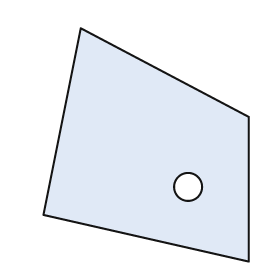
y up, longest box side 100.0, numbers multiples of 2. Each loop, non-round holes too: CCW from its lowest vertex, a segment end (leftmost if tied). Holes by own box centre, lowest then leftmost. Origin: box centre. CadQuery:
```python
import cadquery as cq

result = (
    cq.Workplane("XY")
    .moveTo(44.0, -50.0)
    .lineTo(44.0, 12.0)
    .lineTo(-28.0, 50.0)
    .lineTo(-44.0, -30.0)
    .close()
    .moveTo(18.0, -18.0)
    .circle(6.0)
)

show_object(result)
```